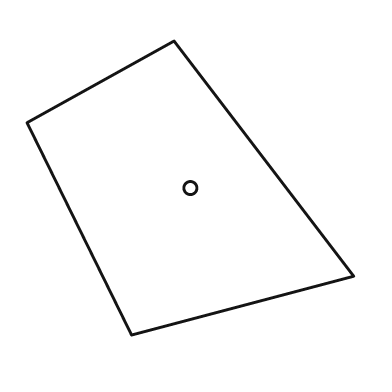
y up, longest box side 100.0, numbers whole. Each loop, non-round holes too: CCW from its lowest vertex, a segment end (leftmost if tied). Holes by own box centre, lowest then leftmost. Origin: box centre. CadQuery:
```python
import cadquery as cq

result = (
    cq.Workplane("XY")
    .moveTo(-18.0, -45.0)
    .lineTo(50.0, -27.0)
    .lineTo(-5.0, 45.0)
    .lineTo(-50.0, 20.0)
    .close()
    .moveTo(0.0, 0.0)
    .circle(2.0)
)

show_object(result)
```